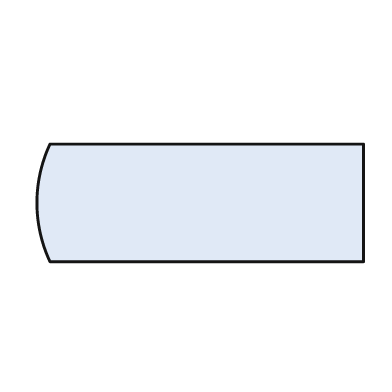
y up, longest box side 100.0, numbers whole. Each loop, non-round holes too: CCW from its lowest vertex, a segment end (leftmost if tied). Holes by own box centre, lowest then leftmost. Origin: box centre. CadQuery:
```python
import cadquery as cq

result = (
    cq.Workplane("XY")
    .moveTo(-46.0, -18.0)
    .lineTo(50.0, -18.0)
    .lineTo(50.0, 18.0)
    .lineTo(-46.0, 18.0)
    .threePointArc((-50.0, 0.0), (-46.0, -18.0))
    .close()
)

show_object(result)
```